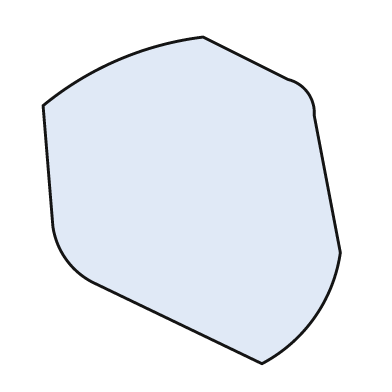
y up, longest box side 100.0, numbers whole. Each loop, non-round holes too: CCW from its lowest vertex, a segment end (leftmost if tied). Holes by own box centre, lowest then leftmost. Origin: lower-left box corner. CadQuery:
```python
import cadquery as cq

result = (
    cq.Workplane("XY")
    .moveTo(67.0, 0.0)
    .threePointArc((83.0, 14.0), (91.0, 34.0))
    .lineTo(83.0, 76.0)
    .threePointArc((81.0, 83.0), (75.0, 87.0))
    .lineTo(49.0, 100.0)
    .threePointArc((23.0, 93.0), (0.0, 79.0))
    .lineTo(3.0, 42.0)
    .threePointArc((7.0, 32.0), (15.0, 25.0))
    .close()
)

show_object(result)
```